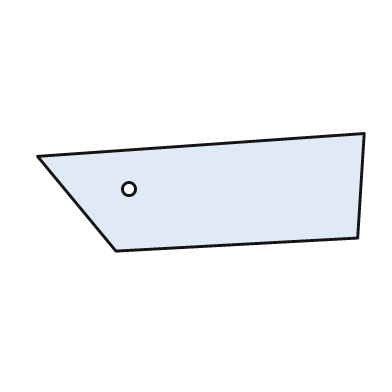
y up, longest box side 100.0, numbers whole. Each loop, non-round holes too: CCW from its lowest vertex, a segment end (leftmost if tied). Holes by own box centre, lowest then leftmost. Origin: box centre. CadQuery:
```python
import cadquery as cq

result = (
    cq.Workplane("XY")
    .moveTo(-26.0, -18.0)
    .lineTo(48.0, -14.0)
    .lineTo(50.0, 18.0)
    .lineTo(-50.0, 11.0)
    .close()
    .moveTo(-22.0, 1.0)
    .circle(2.0)
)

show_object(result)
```